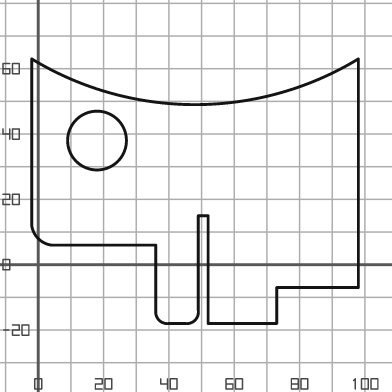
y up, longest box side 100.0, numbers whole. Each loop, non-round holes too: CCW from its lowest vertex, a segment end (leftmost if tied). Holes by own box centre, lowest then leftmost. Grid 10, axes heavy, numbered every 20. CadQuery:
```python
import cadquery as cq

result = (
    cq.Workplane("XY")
    .moveTo(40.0, -18.0)
    .lineTo(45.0, -18.0)
    .threePointArc((48.0, -17.0), (49.0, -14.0))
    .lineTo(49.0, 15.0)
    .lineTo(52.0, 15.0)
    .lineTo(52.0, -18.0)
    .lineTo(73.0, -18.0)
    .lineTo(73.0, -7.0)
    .lineTo(98.0, -7.0)
    .lineTo(98.0, 63.0)
    .threePointArc((48.0, 49.0), (-2.0, 63.0))
    .lineTo(-2.0, 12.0)
    .threePointArc((0.0, 8.0), (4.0, 6.0))
    .lineTo(36.0, 6.0)
    .lineTo(36.0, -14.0)
    .threePointArc((37.0, -17.0), (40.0, -18.0))
    .close()
    .moveTo(18.0, 38.0)
    .circle(9.0)
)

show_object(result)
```